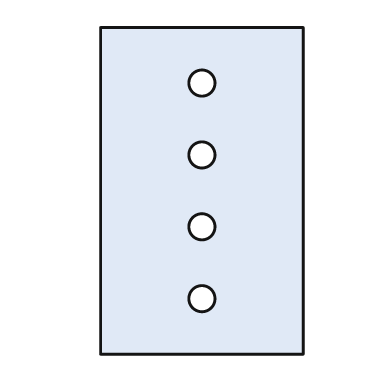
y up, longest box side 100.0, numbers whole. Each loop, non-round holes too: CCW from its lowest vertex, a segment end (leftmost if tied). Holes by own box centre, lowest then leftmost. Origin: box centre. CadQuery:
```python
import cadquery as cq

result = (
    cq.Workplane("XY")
    .moveTo(-31.0, -50.0)
    .lineTo(31.0, -50.0)
    .lineTo(31.0, 50.0)
    .lineTo(-31.0, 50.0)
    .close()
    .moveTo(0.0, -33.0)
    .circle(4.0)
    .moveTo(0.0, -11.0)
    .circle(4.0)
    .moveTo(0.0, 11.0)
    .circle(4.0)
    .moveTo(0.0, 33.0)
    .circle(4.0)
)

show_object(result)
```